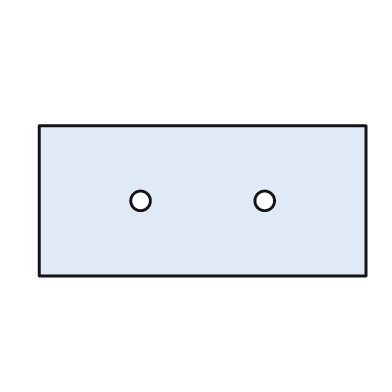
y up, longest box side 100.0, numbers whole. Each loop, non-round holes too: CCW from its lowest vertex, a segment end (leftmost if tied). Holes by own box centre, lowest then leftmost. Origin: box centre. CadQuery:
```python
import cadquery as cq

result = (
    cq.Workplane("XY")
    .moveTo(-50.0, -23.0)
    .lineTo(50.0, -23.0)
    .lineTo(50.0, 23.0)
    .lineTo(-50.0, 23.0)
    .close()
    .moveTo(-19.0, 0.0)
    .circle(3.0)
    .moveTo(19.0, 0.0)
    .circle(3.0)
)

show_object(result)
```